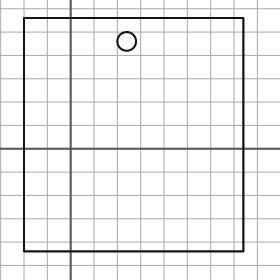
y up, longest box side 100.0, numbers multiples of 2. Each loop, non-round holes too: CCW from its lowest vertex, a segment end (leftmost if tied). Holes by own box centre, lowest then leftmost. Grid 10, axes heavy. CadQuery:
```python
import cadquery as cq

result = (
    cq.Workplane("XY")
    .moveTo(-20.0, -44.0)
    .lineTo(74.0, -44.0)
    .lineTo(74.0, 56.0)
    .lineTo(-20.0, 56.0)
    .close()
    .moveTo(24.0, 46.0)
    .circle(4.0)
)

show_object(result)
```